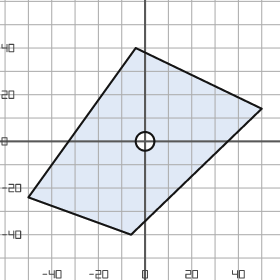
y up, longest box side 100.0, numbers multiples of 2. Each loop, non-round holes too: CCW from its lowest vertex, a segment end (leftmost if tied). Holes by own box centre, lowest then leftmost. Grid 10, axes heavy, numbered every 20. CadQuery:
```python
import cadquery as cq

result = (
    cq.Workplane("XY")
    .moveTo(-6.0, -40.0)
    .lineTo(50.0, 14.0)
    .lineTo(-4.0, 40.0)
    .lineTo(-50.0, -24.0)
    .close()
    .moveTo(0.0, 0.0)
    .circle(4.0)
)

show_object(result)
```